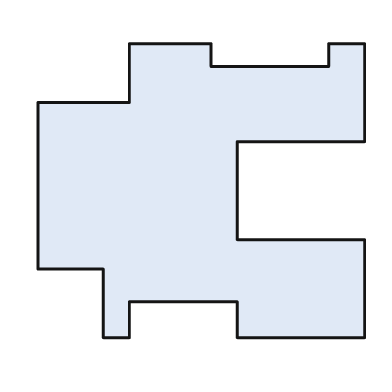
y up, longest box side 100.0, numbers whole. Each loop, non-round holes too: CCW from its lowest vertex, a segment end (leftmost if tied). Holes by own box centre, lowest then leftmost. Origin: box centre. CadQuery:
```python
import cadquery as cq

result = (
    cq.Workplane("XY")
    .moveTo(-30.0, -45.0)
    .lineTo(-22.0, -45.0)
    .lineTo(-22.0, -34.0)
    .lineTo(11.0, -34.0)
    .lineTo(11.0, -45.0)
    .lineTo(50.0, -45.0)
    .lineTo(50.0, -15.0)
    .lineTo(11.0, -15.0)
    .lineTo(11.0, 15.0)
    .lineTo(50.0, 15.0)
    .lineTo(50.0, 45.0)
    .lineTo(39.0, 45.0)
    .lineTo(39.0, 38.0)
    .lineTo(3.0, 38.0)
    .lineTo(3.0, 45.0)
    .lineTo(-22.0, 45.0)
    .lineTo(-22.0, 27.0)
    .lineTo(-50.0, 27.0)
    .lineTo(-50.0, -24.0)
    .lineTo(-30.0, -24.0)
    .close()
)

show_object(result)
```